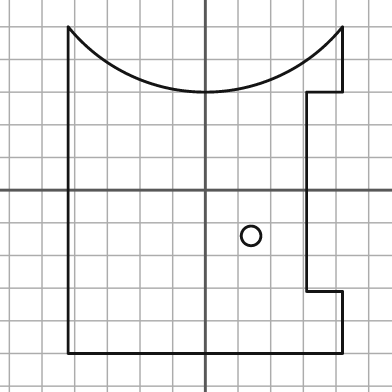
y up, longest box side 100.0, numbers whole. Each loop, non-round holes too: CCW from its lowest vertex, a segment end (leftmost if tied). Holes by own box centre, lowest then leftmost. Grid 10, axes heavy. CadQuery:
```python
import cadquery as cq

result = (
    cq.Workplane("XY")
    .moveTo(-42.0, -50.0)
    .lineTo(42.0, -50.0)
    .lineTo(42.0, -31.0)
    .lineTo(31.0, -31.0)
    .lineTo(31.0, 30.0)
    .lineTo(42.0, 30.0)
    .lineTo(42.0, 50.0)
    .threePointArc((0.0, 30.0), (-42.0, 50.0))
    .close()
    .moveTo(14.0, -14.0)
    .circle(3.0)
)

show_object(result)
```